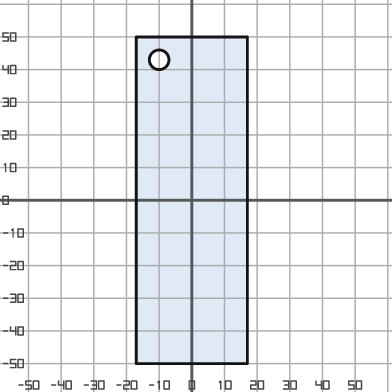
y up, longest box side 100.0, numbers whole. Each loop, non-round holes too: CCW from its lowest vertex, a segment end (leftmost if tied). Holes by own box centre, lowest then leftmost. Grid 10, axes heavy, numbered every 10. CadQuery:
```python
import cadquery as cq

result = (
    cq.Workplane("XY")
    .moveTo(-17.0, -50.0)
    .lineTo(17.0, -50.0)
    .lineTo(17.0, 50.0)
    .lineTo(-17.0, 50.0)
    .close()
    .moveTo(-10.0, 43.0)
    .circle(3.0)
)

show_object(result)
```